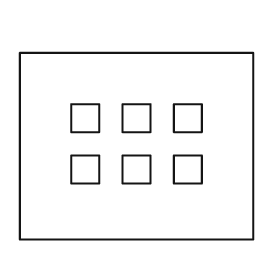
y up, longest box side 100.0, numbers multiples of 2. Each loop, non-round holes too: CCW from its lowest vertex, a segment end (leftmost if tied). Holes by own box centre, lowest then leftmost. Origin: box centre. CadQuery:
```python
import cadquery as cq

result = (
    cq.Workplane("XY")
    .moveTo(-50.0, -40.0)
    .lineTo(50.0, -40.0)
    .lineTo(50.0, 40.0)
    .lineTo(-50.0, 40.0)
    .close()
    .moveTo(-28.0, -16.0)
    .lineTo(-16.0, -16.0)
    .lineTo(-16.0, -4.0)
    .lineTo(-28.0, -4.0)
    .close()
    .moveTo(-6.0, -16.0)
    .lineTo(6.0, -16.0)
    .lineTo(6.0, -4.0)
    .lineTo(-6.0, -4.0)
    .close()
    .moveTo(16.0, -16.0)
    .lineTo(28.0, -16.0)
    .lineTo(28.0, -4.0)
    .lineTo(16.0, -4.0)
    .close()
    .moveTo(-28.0, 6.0)
    .lineTo(-16.0, 6.0)
    .lineTo(-16.0, 18.0)
    .lineTo(-28.0, 18.0)
    .close()
    .moveTo(-6.0, 6.0)
    .lineTo(6.0, 6.0)
    .lineTo(6.0, 18.0)
    .lineTo(-6.0, 18.0)
    .close()
    .moveTo(16.0, 6.0)
    .lineTo(28.0, 6.0)
    .lineTo(28.0, 18.0)
    .lineTo(16.0, 18.0)
    .close()
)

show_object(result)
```